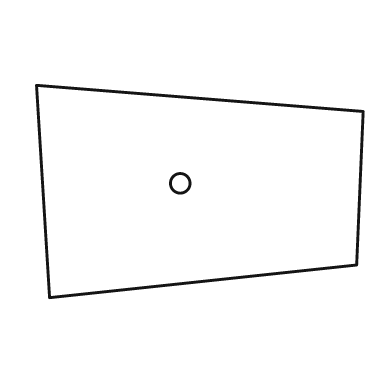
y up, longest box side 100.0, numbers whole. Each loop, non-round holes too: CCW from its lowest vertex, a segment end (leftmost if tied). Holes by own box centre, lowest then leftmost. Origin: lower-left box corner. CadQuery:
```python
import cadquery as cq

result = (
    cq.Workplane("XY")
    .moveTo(4.0, 0.0)
    .lineTo(98.0, 10.0)
    .lineTo(100.0, 57.0)
    .lineTo(0.0, 65.0)
    .close()
    .moveTo(44.0, 35.0)
    .circle(3.0)
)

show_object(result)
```